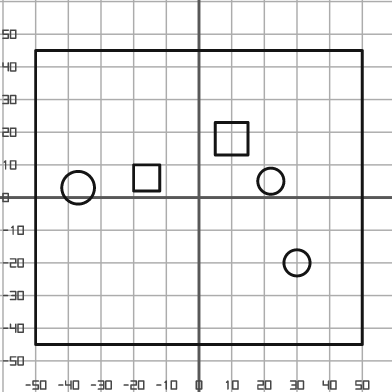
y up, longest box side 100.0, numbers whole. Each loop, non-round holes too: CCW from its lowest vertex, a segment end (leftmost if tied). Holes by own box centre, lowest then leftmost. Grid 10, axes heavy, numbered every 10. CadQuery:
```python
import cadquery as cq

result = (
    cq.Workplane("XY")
    .moveTo(-50.0, -45.0)
    .lineTo(50.0, -45.0)
    .lineTo(50.0, 45.0)
    .lineTo(-50.0, 45.0)
    .close()
    .moveTo(30.0, -20.0)
    .circle(4.0)
    .moveTo(-37.0, 3.0)
    .circle(5.0)
    .moveTo(22.0, 5.0)
    .circle(4.0)
    .moveTo(-20.0, 2.0)
    .lineTo(-12.0, 2.0)
    .lineTo(-12.0, 10.0)
    .lineTo(-20.0, 10.0)
    .close()
    .moveTo(5.0, 13.0)
    .lineTo(15.0, 13.0)
    .lineTo(15.0, 23.0)
    .lineTo(5.0, 23.0)
    .close()
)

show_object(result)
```